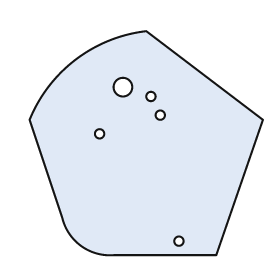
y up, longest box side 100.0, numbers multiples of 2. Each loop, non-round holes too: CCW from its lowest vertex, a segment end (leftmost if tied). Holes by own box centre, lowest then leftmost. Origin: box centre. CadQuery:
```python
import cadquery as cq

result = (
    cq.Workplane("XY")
    .moveTo(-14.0, -48.0)
    .lineTo(30.0, -48.0)
    .lineTo(50.0, 10.0)
    .lineTo(0.0, 48.0)
    .threePointArc((-30.0, 36.0), (-50.0, 10.0))
    .lineTo(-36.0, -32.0)
    .threePointArc((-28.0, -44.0), (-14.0, -48.0))
    .close()
    .moveTo(14.0, -42.0)
    .circle(2.0)
    .moveTo(-20.0, 4.0)
    .circle(2.0)
    .moveTo(6.0, 12.0)
    .circle(2.0)
    .moveTo(2.0, 20.0)
    .circle(2.0)
    .moveTo(-10.0, 24.0)
    .circle(4.0)
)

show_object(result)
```